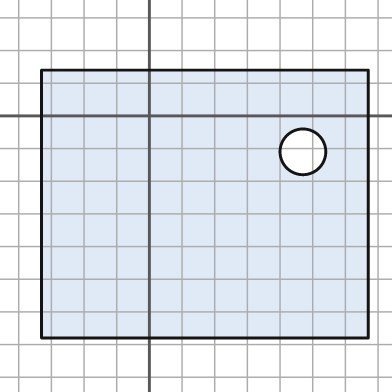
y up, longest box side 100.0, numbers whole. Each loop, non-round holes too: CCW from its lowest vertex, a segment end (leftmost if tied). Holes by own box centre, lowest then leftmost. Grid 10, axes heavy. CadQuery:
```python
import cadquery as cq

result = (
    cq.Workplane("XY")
    .moveTo(-33.0, -68.0)
    .lineTo(67.0, -68.0)
    .lineTo(67.0, 14.0)
    .lineTo(-33.0, 14.0)
    .close()
    .moveTo(47.0, -11.0)
    .circle(7.0)
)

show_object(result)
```